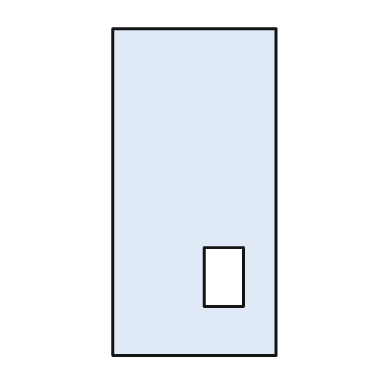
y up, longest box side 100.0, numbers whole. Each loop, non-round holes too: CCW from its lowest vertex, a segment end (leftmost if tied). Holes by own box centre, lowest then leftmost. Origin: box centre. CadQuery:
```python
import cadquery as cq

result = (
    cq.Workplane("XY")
    .moveTo(-25.0, -50.0)
    .lineTo(25.0, -50.0)
    .lineTo(25.0, 50.0)
    .lineTo(-25.0, 50.0)
    .close()
    .moveTo(3.0, -35.0)
    .lineTo(15.0, -35.0)
    .lineTo(15.0, -17.0)
    .lineTo(3.0, -17.0)
    .close()
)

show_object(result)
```